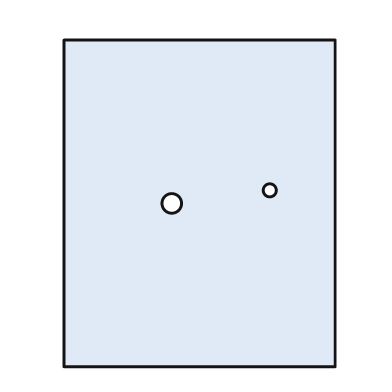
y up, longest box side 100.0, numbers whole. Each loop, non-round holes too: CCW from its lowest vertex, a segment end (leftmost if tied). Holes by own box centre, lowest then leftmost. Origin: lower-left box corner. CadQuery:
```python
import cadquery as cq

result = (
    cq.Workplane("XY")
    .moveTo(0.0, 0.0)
    .lineTo(83.0, 0.0)
    .lineTo(83.0, 100.0)
    .lineTo(0.0, 100.0)
    .close()
    .moveTo(33.0, 50.0)
    .circle(3.0)
    .moveTo(63.0, 54.0)
    .circle(2.0)
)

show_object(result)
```